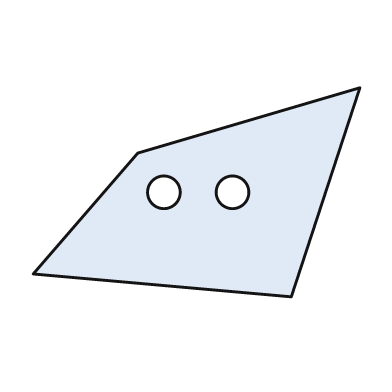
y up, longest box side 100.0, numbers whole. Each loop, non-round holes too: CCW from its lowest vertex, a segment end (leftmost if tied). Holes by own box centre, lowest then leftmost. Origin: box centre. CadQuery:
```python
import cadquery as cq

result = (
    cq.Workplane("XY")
    .moveTo(29.0, -32.0)
    .lineTo(50.0, 32.0)
    .lineTo(-18.0, 12.0)
    .lineTo(-50.0, -25.0)
    .close()
    .moveTo(-10.0, 0.0)
    .circle(5.0)
    .moveTo(11.0, 0.0)
    .circle(5.0)
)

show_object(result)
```